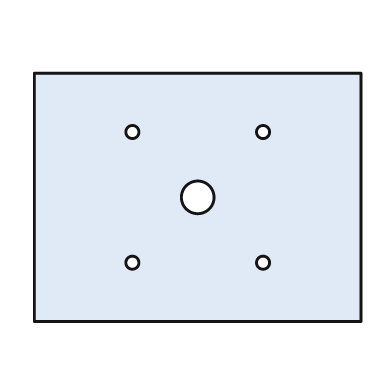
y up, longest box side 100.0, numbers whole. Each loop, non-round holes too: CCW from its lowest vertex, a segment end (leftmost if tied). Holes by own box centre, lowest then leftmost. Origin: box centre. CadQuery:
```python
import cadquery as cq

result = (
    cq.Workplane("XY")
    .moveTo(-50.0, -38.0)
    .lineTo(50.0, -38.0)
    .lineTo(50.0, 38.0)
    .lineTo(-50.0, 38.0)
    .close()
    .moveTo(-20.0, -20.0)
    .circle(2.0)
    .moveTo(20.0, -20.0)
    .circle(2.0)
    .moveTo(0.0, 0.0)
    .circle(5.0)
    .moveTo(-20.0, 20.0)
    .circle(2.0)
    .moveTo(20.0, 20.0)
    .circle(2.0)
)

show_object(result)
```